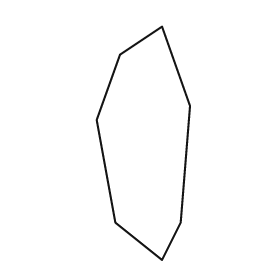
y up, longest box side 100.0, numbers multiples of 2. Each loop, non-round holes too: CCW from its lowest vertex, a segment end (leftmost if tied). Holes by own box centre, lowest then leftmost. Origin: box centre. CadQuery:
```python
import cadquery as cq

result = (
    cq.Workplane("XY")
    .moveTo(8.0, -50.0)
    .lineTo(16.0, -34.0)
    .lineTo(20.0, 16.0)
    .lineTo(8.0, 50.0)
    .lineTo(-10.0, 38.0)
    .lineTo(-20.0, 10.0)
    .lineTo(-12.0, -34.0)
    .close()
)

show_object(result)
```